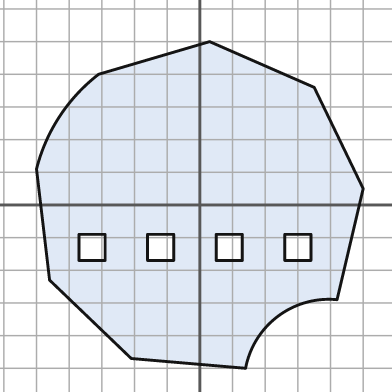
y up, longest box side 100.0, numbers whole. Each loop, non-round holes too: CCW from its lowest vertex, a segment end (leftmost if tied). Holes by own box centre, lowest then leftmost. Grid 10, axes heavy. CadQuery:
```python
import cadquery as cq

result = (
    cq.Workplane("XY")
    .moveTo(14.0, -50.0)
    .threePointArc((24.0, -34.0), (42.0, -29.0))
    .lineTo(50.0, 5.0)
    .lineTo(35.0, 36.0)
    .lineTo(3.0, 50.0)
    .lineTo(-31.0, 40.0)
    .threePointArc((-43.0, 27.0), (-50.0, 11.0))
    .lineTo(-46.0, -23.0)
    .lineTo(-21.0, -47.0)
    .close()
    .moveTo(-37.0, -17.0)
    .lineTo(-29.0, -17.0)
    .lineTo(-29.0, -9.0)
    .lineTo(-37.0, -9.0)
    .close()
    .moveTo(-16.0, -17.0)
    .lineTo(-8.0, -17.0)
    .lineTo(-8.0, -9.0)
    .lineTo(-16.0, -9.0)
    .close()
    .moveTo(5.0, -17.0)
    .lineTo(13.0, -17.0)
    .lineTo(13.0, -9.0)
    .lineTo(5.0, -9.0)
    .close()
    .moveTo(26.0, -17.0)
    .lineTo(34.0, -17.0)
    .lineTo(34.0, -9.0)
    .lineTo(26.0, -9.0)
    .close()
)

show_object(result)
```